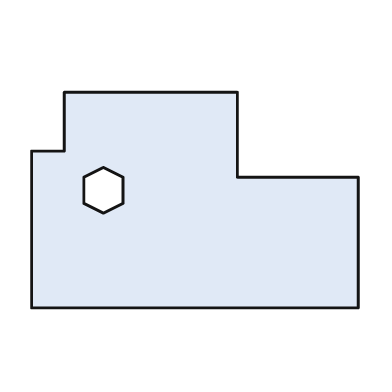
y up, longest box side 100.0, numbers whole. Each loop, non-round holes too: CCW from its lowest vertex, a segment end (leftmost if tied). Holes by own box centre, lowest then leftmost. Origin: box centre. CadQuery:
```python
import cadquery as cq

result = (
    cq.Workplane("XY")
    .moveTo(-50.0, -33.0)
    .lineTo(50.0, -33.0)
    .lineTo(50.0, 7.0)
    .lineTo(13.0, 7.0)
    .lineTo(13.0, 33.0)
    .lineTo(-40.0, 33.0)
    .lineTo(-40.0, 15.0)
    .lineTo(-50.0, 15.0)
    .close()
    .moveTo(-28.0, -4.0)
    .lineTo(-22.0, -1.0)
    .lineTo(-22.0, 7.0)
    .lineTo(-28.0, 10.0)
    .lineTo(-34.0, 7.0)
    .lineTo(-34.0, -1.0)
    .close()
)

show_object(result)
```